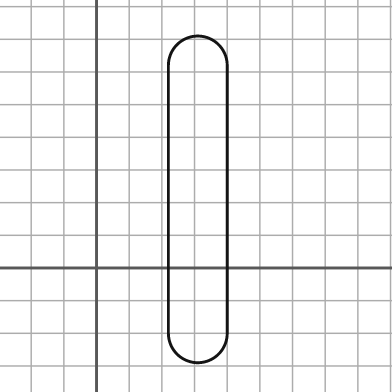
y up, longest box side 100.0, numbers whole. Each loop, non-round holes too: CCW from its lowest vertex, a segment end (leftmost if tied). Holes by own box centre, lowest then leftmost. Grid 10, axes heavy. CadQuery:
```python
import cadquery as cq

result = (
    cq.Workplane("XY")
    .moveTo(22.0, -20.0)
    .threePointArc((31.0, -29.0), (40.0, -20.0))
    .lineTo(40.0, 62.0)
    .threePointArc((31.0, 71.0), (22.0, 62.0))
    .close()
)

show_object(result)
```